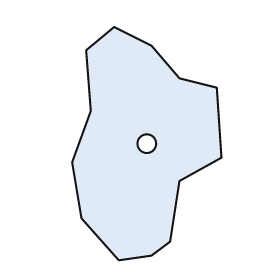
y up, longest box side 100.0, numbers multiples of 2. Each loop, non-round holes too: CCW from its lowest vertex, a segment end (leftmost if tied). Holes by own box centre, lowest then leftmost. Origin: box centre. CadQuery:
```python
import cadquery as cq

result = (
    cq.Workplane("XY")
    .moveTo(-12.0, -50.0)
    .lineTo(2.0, -48.0)
    .lineTo(10.0, -42.0)
    .lineTo(14.0, -16.0)
    .lineTo(32.0, -6.0)
    .lineTo(30.0, 24.0)
    .lineTo(14.0, 28.0)
    .lineTo(2.0, 42.0)
    .lineTo(-14.0, 50.0)
    .lineTo(-26.0, 40.0)
    .lineTo(-24.0, 14.0)
    .lineTo(-32.0, -8.0)
    .lineTo(-28.0, -32.0)
    .close()
    .moveTo(0.0, 0.0)
    .circle(4.0)
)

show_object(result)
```